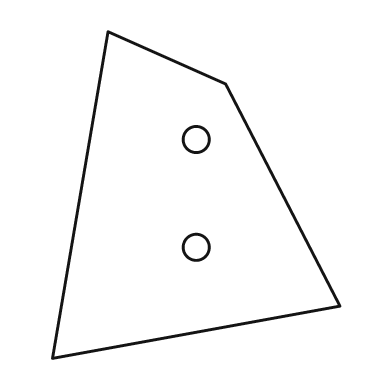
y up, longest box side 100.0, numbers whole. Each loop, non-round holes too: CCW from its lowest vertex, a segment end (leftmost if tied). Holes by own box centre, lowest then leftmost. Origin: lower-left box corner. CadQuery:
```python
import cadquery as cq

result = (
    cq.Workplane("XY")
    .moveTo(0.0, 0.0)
    .lineTo(88.0, 16.0)
    .lineTo(53.0, 84.0)
    .lineTo(17.0, 100.0)
    .close()
    .moveTo(44.0, 34.0)
    .circle(4.0)
    .moveTo(44.0, 67.0)
    .circle(4.0)
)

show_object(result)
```